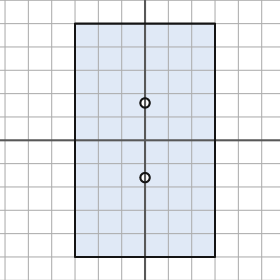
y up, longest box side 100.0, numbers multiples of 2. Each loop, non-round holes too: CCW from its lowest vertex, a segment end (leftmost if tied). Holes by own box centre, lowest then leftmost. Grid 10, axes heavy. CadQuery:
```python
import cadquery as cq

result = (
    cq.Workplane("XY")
    .moveTo(-30.0, -50.0)
    .lineTo(30.0, -50.0)
    .lineTo(30.0, 50.0)
    .lineTo(-30.0, 50.0)
    .close()
    .moveTo(0.0, -16.0)
    .circle(2.0)
    .moveTo(0.0, 16.0)
    .circle(2.0)
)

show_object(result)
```